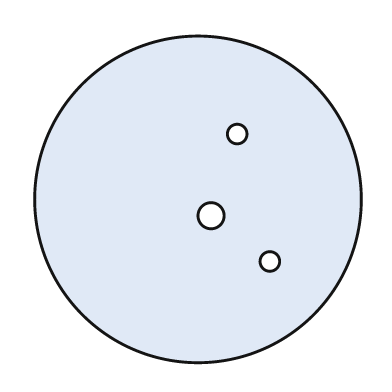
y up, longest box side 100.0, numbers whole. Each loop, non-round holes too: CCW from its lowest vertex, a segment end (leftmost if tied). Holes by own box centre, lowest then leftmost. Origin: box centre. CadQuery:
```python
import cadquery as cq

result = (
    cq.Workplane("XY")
    .moveTo(0.0, 0.0)
    .circle(50.0)
    .moveTo(22.0, -19.0)
    .circle(3.0)
    .moveTo(4.0, -5.0)
    .circle(4.0)
    .moveTo(12.0, 20.0)
    .circle(3.0)
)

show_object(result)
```